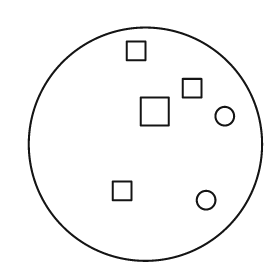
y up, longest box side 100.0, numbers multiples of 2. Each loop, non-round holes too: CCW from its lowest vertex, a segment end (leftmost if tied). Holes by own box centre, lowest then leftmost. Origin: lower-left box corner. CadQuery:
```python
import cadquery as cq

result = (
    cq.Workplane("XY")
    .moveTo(50.0, 50.0)
    .circle(50.0)
    .moveTo(76.0, 26.0)
    .circle(4.0)
    .moveTo(36.0, 26.0)
    .lineTo(44.0, 26.0)
    .lineTo(44.0, 34.0)
    .lineTo(36.0, 34.0)
    .close()
    .moveTo(84.0, 62.0)
    .circle(4.0)
    .moveTo(48.0, 58.0)
    .lineTo(60.0, 58.0)
    .lineTo(60.0, 70.0)
    .lineTo(48.0, 70.0)
    .close()
    .moveTo(66.0, 70.0)
    .lineTo(74.0, 70.0)
    .lineTo(74.0, 78.0)
    .lineTo(66.0, 78.0)
    .close()
    .moveTo(42.0, 86.0)
    .lineTo(50.0, 86.0)
    .lineTo(50.0, 94.0)
    .lineTo(42.0, 94.0)
    .close()
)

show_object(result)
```